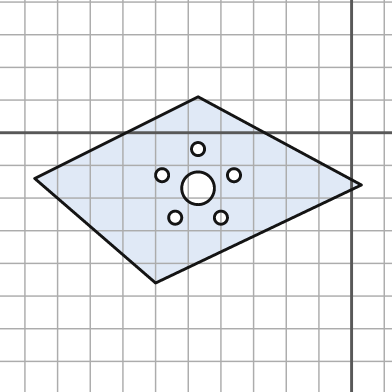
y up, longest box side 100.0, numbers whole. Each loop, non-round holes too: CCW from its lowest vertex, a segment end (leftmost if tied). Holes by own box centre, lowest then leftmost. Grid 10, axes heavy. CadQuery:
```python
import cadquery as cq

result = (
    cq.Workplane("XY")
    .moveTo(-60.0, -46.0)
    .lineTo(3.0, -16.0)
    .lineTo(-47.0, 11.0)
    .lineTo(-97.0, -14.0)
    .close()
    .moveTo(-54.0, -26.0)
    .circle(2.0)
    .moveTo(-40.0, -26.0)
    .circle(2.0)
    .moveTo(-47.0, -17.0)
    .circle(5.0)
    .moveTo(-58.0, -13.0)
    .circle(2.0)
    .moveTo(-36.0, -13.0)
    .circle(2.0)
    .moveTo(-47.0, -5.0)
    .circle(2.0)
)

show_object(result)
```